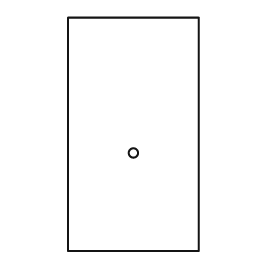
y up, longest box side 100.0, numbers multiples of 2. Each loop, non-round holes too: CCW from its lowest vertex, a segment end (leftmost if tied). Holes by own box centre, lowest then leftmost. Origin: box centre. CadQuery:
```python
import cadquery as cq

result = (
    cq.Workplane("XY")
    .moveTo(-28.0, -50.0)
    .lineTo(28.0, -50.0)
    .lineTo(28.0, 50.0)
    .lineTo(-28.0, 50.0)
    .close()
    .moveTo(0.0, -8.0)
    .circle(2.0)
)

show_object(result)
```